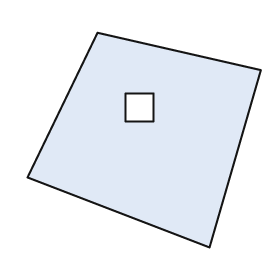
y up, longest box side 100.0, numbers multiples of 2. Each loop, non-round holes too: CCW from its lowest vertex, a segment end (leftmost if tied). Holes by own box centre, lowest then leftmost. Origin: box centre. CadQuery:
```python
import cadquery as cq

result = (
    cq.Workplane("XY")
    .moveTo(28.0, -46.0)
    .lineTo(50.0, 30.0)
    .lineTo(-20.0, 46.0)
    .lineTo(-50.0, -16.0)
    .close()
    .moveTo(-8.0, 8.0)
    .lineTo(4.0, 8.0)
    .lineTo(4.0, 20.0)
    .lineTo(-8.0, 20.0)
    .close()
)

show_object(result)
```